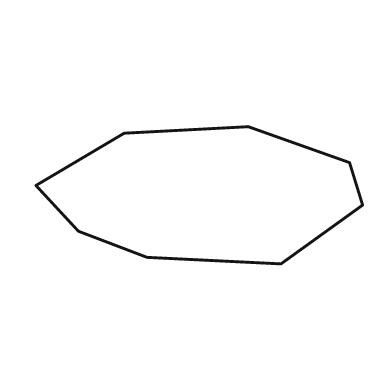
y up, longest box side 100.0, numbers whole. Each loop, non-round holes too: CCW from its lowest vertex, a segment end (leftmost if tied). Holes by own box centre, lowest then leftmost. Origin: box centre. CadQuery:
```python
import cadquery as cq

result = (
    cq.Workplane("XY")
    .moveTo(25.0, -21.0)
    .lineTo(50.0, -3.0)
    .lineTo(46.0, 10.0)
    .lineTo(15.0, 21.0)
    .lineTo(-23.0, 19.0)
    .lineTo(-50.0, 3.0)
    .lineTo(-37.0, -11.0)
    .lineTo(-16.0, -19.0)
    .close()
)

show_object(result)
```